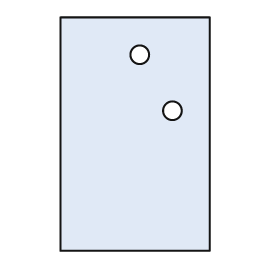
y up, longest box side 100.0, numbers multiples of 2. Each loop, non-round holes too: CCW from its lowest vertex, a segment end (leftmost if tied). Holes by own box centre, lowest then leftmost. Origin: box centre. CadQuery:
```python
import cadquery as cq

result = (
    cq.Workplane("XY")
    .moveTo(-32.0, -50.0)
    .lineTo(32.0, -50.0)
    .lineTo(32.0, 50.0)
    .lineTo(-32.0, 50.0)
    .close()
    .moveTo(16.0, 10.0)
    .circle(4.0)
    .moveTo(2.0, 34.0)
    .circle(4.0)
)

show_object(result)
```